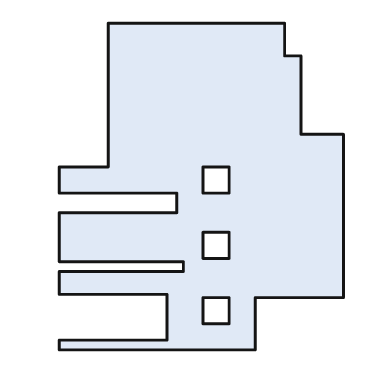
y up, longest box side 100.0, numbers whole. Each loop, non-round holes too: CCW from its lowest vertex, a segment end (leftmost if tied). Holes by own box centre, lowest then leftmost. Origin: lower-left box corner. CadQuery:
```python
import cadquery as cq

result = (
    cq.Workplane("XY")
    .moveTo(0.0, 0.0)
    .lineTo(60.0, 0.0)
    .lineTo(60.0, 16.0)
    .lineTo(87.0, 16.0)
    .lineTo(87.0, 66.0)
    .lineTo(74.0, 66.0)
    .lineTo(74.0, 90.0)
    .lineTo(69.0, 90.0)
    .lineTo(69.0, 100.0)
    .lineTo(15.0, 100.0)
    .lineTo(15.0, 56.0)
    .lineTo(0.0, 56.0)
    .lineTo(0.0, 48.0)
    .lineTo(36.0, 48.0)
    .lineTo(36.0, 42.0)
    .lineTo(0.0, 42.0)
    .lineTo(0.0, 27.0)
    .lineTo(38.0, 27.0)
    .lineTo(38.0, 24.0)
    .lineTo(0.0, 24.0)
    .lineTo(0.0, 17.0)
    .lineTo(33.0, 17.0)
    .lineTo(33.0, 3.0)
    .lineTo(0.0, 3.0)
    .close()
    .moveTo(44.0, 8.0)
    .lineTo(52.0, 8.0)
    .lineTo(52.0, 16.0)
    .lineTo(44.0, 16.0)
    .close()
    .moveTo(44.0, 28.0)
    .lineTo(52.0, 28.0)
    .lineTo(52.0, 36.0)
    .lineTo(44.0, 36.0)
    .close()
    .moveTo(44.0, 48.0)
    .lineTo(52.0, 48.0)
    .lineTo(52.0, 56.0)
    .lineTo(44.0, 56.0)
    .close()
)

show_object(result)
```